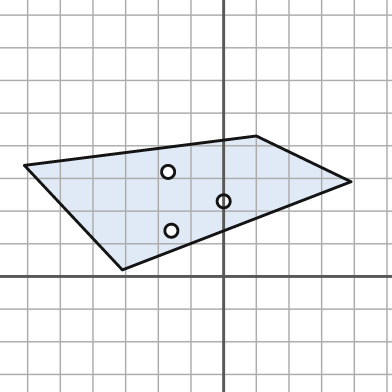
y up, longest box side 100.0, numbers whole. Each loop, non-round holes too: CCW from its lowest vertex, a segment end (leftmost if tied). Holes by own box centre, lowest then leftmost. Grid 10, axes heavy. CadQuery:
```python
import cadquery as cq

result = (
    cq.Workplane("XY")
    .moveTo(-31.0, 2.0)
    .lineTo(39.0, 29.0)
    .lineTo(10.0, 43.0)
    .lineTo(-61.0, 34.0)
    .close()
    .moveTo(-16.0, 14.0)
    .circle(2.0)
    .moveTo(0.0, 23.0)
    .circle(2.0)
    .moveTo(-17.0, 32.0)
    .circle(2.0)
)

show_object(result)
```